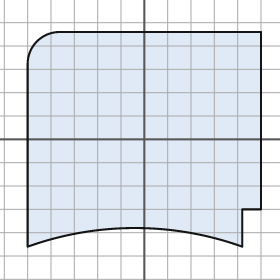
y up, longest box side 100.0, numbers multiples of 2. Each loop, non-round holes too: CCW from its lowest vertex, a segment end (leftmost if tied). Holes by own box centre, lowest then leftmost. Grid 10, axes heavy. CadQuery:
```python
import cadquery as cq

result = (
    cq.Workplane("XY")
    .moveTo(-50.0, -46.0)
    .threePointArc((-4.0, -38.0), (42.0, -46.0))
    .lineTo(42.0, -30.0)
    .lineTo(50.0, -30.0)
    .lineTo(50.0, 46.0)
    .lineTo(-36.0, 46.0)
    .threePointArc((-46.0, 42.0), (-50.0, 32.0))
    .close()
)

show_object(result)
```